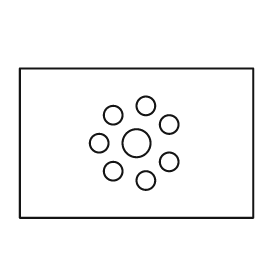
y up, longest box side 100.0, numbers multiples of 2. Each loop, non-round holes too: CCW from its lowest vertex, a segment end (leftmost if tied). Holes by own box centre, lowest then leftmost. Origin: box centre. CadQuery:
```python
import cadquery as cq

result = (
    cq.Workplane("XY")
    .moveTo(-50.0, -32.0)
    .lineTo(50.0, -32.0)
    .lineTo(50.0, 32.0)
    .lineTo(-50.0, 32.0)
    .close()
    .moveTo(4.0, -16.0)
    .circle(4.0)
    .moveTo(-10.0, -12.0)
    .circle(4.0)
    .moveTo(14.0, -8.0)
    .circle(4.0)
    .moveTo(-16.0, 0.0)
    .circle(4.0)
    .moveTo(0.0, 0.0)
    .circle(6.0)
    .moveTo(14.0, 8.0)
    .circle(4.0)
    .moveTo(-10.0, 12.0)
    .circle(4.0)
    .moveTo(4.0, 16.0)
    .circle(4.0)
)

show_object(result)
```